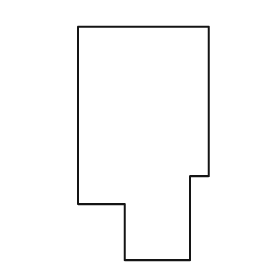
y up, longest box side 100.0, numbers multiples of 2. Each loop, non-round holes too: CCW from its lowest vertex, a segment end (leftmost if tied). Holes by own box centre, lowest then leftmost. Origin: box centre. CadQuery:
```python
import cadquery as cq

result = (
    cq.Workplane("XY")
    .moveTo(-8.0, -50.0)
    .lineTo(20.0, -50.0)
    .lineTo(20.0, -14.0)
    .lineTo(28.0, -14.0)
    .lineTo(28.0, 50.0)
    .lineTo(-28.0, 50.0)
    .lineTo(-28.0, -26.0)
    .lineTo(-8.0, -26.0)
    .close()
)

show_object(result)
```